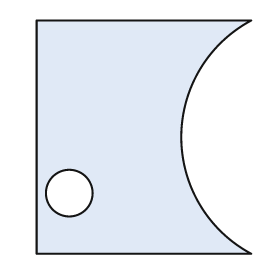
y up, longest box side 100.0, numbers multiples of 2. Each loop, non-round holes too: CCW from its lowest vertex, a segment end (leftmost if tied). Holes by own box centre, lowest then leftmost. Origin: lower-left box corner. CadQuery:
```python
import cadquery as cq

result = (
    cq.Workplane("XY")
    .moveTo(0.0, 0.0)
    .lineTo(92.0, 0.0)
    .threePointArc((62.0, 50.0), (92.0, 100.0))
    .lineTo(0.0, 100.0)
    .close()
    .moveTo(14.0, 26.0)
    .circle(10.0)
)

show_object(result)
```